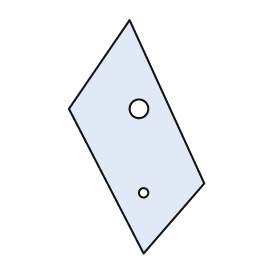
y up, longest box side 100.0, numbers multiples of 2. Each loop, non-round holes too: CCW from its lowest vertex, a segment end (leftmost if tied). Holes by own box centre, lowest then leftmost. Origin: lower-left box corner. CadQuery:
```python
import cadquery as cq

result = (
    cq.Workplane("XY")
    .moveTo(32.0, 0.0)
    .lineTo(58.0, 30.0)
    .lineTo(26.0, 100.0)
    .lineTo(0.0, 62.0)
    .close()
    .moveTo(32.0, 26.0)
    .circle(2.0)
    .moveTo(30.0, 62.0)
    .circle(4.0)
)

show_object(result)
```